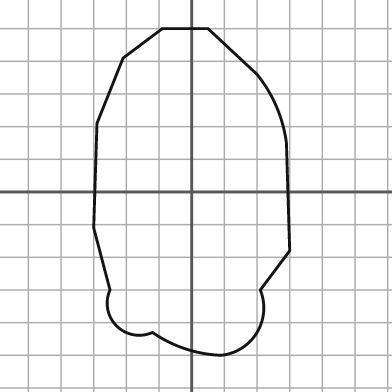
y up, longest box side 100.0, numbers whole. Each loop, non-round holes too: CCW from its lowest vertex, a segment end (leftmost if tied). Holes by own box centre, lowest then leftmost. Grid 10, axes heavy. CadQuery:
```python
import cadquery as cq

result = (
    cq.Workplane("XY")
    .moveTo(9.0, -50.0)
    .threePointArc((20.0, -43.0), (21.0, -30.0))
    .lineTo(30.0, -18.0)
    .lineTo(29.0, 15.0)
    .threePointArc((26.0, 26.0), (20.0, 36.0))
    .lineTo(5.0, 50.0)
    .lineTo(-9.0, 50.0)
    .lineTo(-21.0, 41.0)
    .lineTo(-29.0, 21.0)
    .lineTo(-30.0, -11.0)
    .lineTo(-25.0, -30.0)
    .threePointArc((-23.0, -41.0), (-12.0, -43.0))
    .threePointArc((-2.0, -48.0), (9.0, -50.0))
    .close()
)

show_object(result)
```